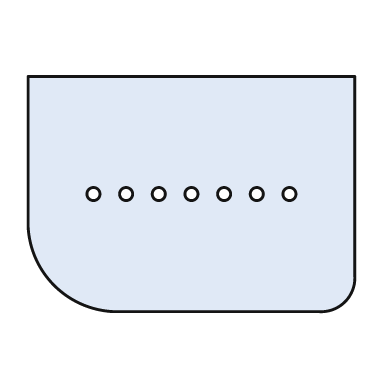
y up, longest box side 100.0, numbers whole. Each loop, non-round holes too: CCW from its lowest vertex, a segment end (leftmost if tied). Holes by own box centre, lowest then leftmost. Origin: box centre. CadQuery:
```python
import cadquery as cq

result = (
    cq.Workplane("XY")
    .moveTo(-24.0, -36.0)
    .lineTo(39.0, -36.0)
    .threePointArc((47.0, -33.0), (50.0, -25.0))
    .lineTo(50.0, 36.0)
    .lineTo(-50.0, 36.0)
    .lineTo(-50.0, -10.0)
    .threePointArc((-42.0, -28.0), (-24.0, -36.0))
    .close()
    .moveTo(-30.0, 0.0)
    .circle(2.0)
    .moveTo(-20.0, 0.0)
    .circle(2.0)
    .moveTo(-10.0, 0.0)
    .circle(2.0)
    .moveTo(0.0, 0.0)
    .circle(2.0)
    .moveTo(10.0, 0.0)
    .circle(2.0)
    .moveTo(20.0, 0.0)
    .circle(2.0)
    .moveTo(30.0, 0.0)
    .circle(2.0)
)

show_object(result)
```